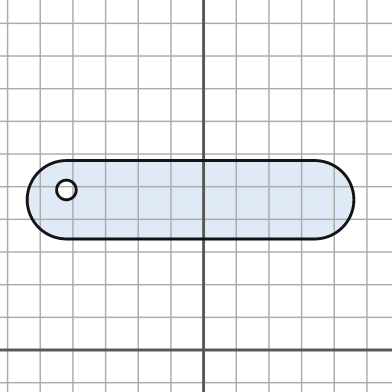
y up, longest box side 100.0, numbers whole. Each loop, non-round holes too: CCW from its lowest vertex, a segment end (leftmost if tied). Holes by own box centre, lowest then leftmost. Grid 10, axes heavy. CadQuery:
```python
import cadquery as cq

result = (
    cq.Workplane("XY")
    .moveTo(-42.0, 34.0)
    .lineTo(34.0, 34.0)
    .threePointArc((46.0, 46.0), (34.0, 58.0))
    .lineTo(-42.0, 58.0)
    .threePointArc((-54.0, 46.0), (-42.0, 34.0))
    .close()
    .moveTo(-42.0, 49.0)
    .circle(3.0)
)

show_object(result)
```